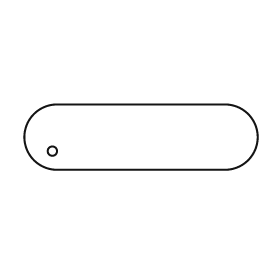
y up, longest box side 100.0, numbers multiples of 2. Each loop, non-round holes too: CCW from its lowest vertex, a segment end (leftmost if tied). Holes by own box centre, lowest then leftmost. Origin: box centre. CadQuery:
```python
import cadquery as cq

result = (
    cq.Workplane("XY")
    .moveTo(-36.0, -14.0)
    .lineTo(36.0, -14.0)
    .threePointArc((50.0, 0.0), (36.0, 14.0))
    .lineTo(-36.0, 14.0)
    .threePointArc((-50.0, 0.0), (-36.0, -14.0))
    .close()
    .moveTo(-38.0, -6.0)
    .circle(2.0)
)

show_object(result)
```